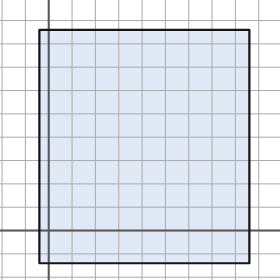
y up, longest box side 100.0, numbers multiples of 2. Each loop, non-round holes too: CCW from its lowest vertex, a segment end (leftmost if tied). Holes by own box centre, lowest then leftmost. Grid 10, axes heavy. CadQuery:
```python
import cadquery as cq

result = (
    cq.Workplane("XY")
    .moveTo(-4.0, -14.0)
    .lineTo(86.0, -14.0)
    .lineTo(86.0, 86.0)
    .lineTo(-4.0, 86.0)
    .close()
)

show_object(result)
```